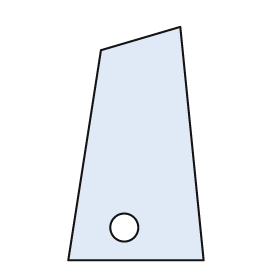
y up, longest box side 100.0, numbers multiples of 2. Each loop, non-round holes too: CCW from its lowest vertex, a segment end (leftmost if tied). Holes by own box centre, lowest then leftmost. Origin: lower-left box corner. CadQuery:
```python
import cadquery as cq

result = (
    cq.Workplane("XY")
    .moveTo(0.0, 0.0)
    .lineTo(58.0, 0.0)
    .lineTo(48.0, 100.0)
    .lineTo(14.0, 90.0)
    .close()
    .moveTo(24.0, 14.0)
    .circle(6.0)
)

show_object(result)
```